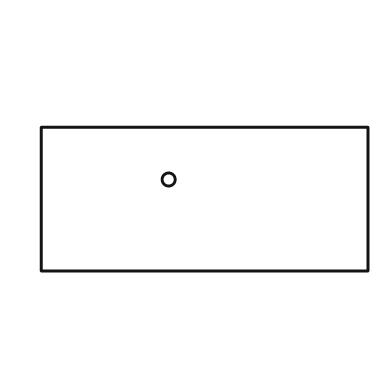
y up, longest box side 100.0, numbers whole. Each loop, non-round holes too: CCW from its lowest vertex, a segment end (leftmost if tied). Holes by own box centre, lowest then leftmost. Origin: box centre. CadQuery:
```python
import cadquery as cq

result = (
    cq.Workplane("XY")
    .moveTo(-50.0, -22.0)
    .lineTo(50.0, -22.0)
    .lineTo(50.0, 22.0)
    .lineTo(-50.0, 22.0)
    .close()
    .moveTo(-11.0, 6.0)
    .circle(2.0)
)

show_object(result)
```